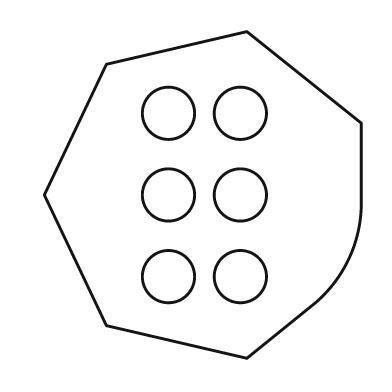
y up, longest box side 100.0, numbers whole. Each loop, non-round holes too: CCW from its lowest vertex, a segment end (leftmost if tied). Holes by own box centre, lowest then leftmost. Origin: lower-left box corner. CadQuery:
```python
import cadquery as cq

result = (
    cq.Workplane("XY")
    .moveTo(62.0, 0.0)
    .lineTo(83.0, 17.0)
    .threePointArc((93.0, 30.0), (97.0, 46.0))
    .lineTo(97.0, 72.0)
    .lineTo(62.0, 100.0)
    .lineTo(19.0, 90.0)
    .lineTo(0.0, 50.0)
    .lineTo(19.0, 10.0)
    .close()
    .moveTo(38.0, 25.0)
    .circle(8.0)
    .moveTo(60.0, 25.0)
    .circle(8.0)
    .moveTo(38.0, 50.0)
    .circle(8.0)
    .moveTo(60.0, 50.0)
    .circle(8.0)
    .moveTo(38.0, 75.0)
    .circle(8.0)
    .moveTo(60.0, 75.0)
    .circle(8.0)
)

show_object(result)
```